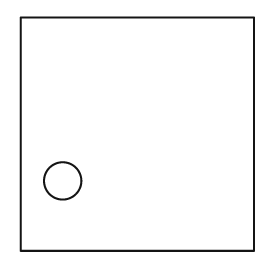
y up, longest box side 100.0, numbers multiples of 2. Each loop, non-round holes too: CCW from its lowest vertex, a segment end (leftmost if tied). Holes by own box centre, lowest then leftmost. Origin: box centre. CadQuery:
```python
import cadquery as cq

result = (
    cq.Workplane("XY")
    .moveTo(-50.0, -50.0)
    .lineTo(50.0, -50.0)
    .lineTo(50.0, 50.0)
    .lineTo(-50.0, 50.0)
    .close()
    .moveTo(-32.0, -20.0)
    .circle(8.0)
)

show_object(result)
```